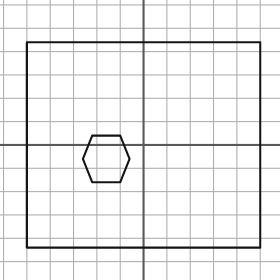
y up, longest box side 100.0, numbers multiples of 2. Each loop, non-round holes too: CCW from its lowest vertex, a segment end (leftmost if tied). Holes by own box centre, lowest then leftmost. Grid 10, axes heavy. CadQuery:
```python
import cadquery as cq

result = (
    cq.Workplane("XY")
    .moveTo(-50.0, -44.0)
    .lineTo(50.0, -44.0)
    .lineTo(50.0, 44.0)
    .lineTo(-50.0, 44.0)
    .close()
    .moveTo(-22.0, -16.0)
    .lineTo(-10.0, -16.0)
    .lineTo(-6.0, -6.0)
    .lineTo(-10.0, 4.0)
    .lineTo(-22.0, 4.0)
    .lineTo(-26.0, -6.0)
    .close()
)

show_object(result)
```